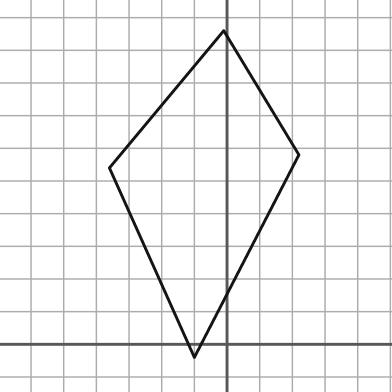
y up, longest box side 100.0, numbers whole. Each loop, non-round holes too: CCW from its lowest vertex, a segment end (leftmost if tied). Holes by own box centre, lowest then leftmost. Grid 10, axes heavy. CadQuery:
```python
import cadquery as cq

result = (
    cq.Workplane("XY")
    .moveTo(-10.0, -4.0)
    .lineTo(22.0, 58.0)
    .lineTo(-1.0, 96.0)
    .lineTo(-36.0, 54.0)
    .close()
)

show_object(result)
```